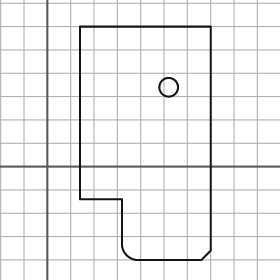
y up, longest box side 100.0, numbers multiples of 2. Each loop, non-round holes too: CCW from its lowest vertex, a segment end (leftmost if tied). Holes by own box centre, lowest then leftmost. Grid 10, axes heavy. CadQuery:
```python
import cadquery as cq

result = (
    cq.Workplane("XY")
    .moveTo(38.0, -40.0)
    .lineTo(66.0, -40.0)
    .lineTo(70.0, -36.0)
    .lineTo(70.0, 60.0)
    .lineTo(14.0, 60.0)
    .lineTo(14.0, -14.0)
    .lineTo(32.0, -14.0)
    .lineTo(32.0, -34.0)
    .threePointArc((34.0, -38.0), (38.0, -40.0))
    .close()
    .moveTo(52.0, 34.0)
    .circle(4.0)
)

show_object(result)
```